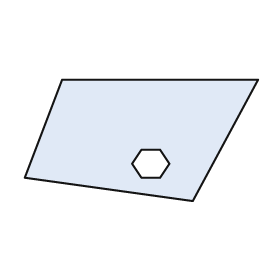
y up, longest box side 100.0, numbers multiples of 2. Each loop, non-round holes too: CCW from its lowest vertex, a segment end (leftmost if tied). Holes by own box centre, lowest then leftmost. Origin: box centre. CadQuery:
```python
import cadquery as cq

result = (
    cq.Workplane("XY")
    .moveTo(22.0, -26.0)
    .lineTo(50.0, 26.0)
    .lineTo(-34.0, 26.0)
    .lineTo(-50.0, -16.0)
    .close()
    .moveTo(0.0, -16.0)
    .lineTo(8.0, -16.0)
    .lineTo(12.0, -10.0)
    .lineTo(8.0, -4.0)
    .lineTo(0.0, -4.0)
    .lineTo(-4.0, -10.0)
    .close()
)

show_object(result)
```